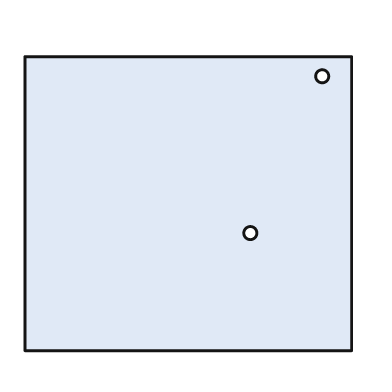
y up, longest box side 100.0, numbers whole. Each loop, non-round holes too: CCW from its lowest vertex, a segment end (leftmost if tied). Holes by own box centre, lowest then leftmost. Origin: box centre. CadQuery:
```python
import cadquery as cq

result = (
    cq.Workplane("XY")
    .moveTo(-50.0, -45.0)
    .lineTo(50.0, -45.0)
    .lineTo(50.0, 45.0)
    .lineTo(-50.0, 45.0)
    .close()
    .moveTo(19.0, -9.0)
    .circle(2.0)
    .moveTo(41.0, 39.0)
    .circle(2.0)
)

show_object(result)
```